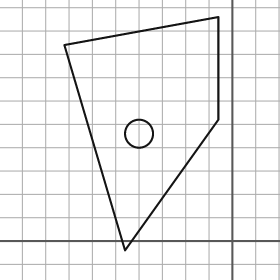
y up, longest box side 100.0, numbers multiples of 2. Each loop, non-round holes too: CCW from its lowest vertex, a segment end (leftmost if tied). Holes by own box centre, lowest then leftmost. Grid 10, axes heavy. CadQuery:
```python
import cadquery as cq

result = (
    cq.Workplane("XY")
    .moveTo(-46.0, -4.0)
    .lineTo(-6.0, 52.0)
    .lineTo(-6.0, 96.0)
    .lineTo(-72.0, 84.0)
    .close()
    .moveTo(-40.0, 46.0)
    .circle(6.0)
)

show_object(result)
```